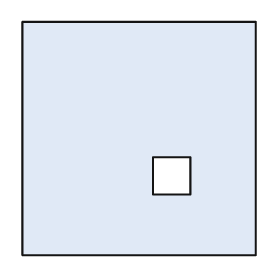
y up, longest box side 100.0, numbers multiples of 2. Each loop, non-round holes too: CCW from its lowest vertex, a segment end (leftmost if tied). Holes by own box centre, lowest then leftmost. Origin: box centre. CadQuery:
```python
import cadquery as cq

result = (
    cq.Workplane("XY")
    .moveTo(-50.0, -50.0)
    .lineTo(50.0, -50.0)
    .lineTo(50.0, 50.0)
    .lineTo(-50.0, 50.0)
    .close()
    .moveTo(6.0, -24.0)
    .lineTo(22.0, -24.0)
    .lineTo(22.0, -8.0)
    .lineTo(6.0, -8.0)
    .close()
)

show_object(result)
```